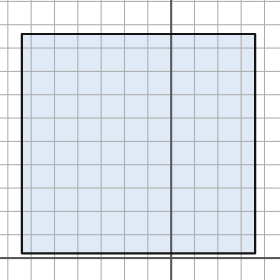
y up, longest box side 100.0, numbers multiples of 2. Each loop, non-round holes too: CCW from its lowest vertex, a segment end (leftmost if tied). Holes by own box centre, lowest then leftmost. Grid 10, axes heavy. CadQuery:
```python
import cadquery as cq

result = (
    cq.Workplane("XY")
    .moveTo(-64.0, 2.0)
    .lineTo(36.0, 2.0)
    .lineTo(36.0, 96.0)
    .lineTo(-64.0, 96.0)
    .close()
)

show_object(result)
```